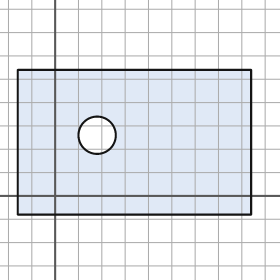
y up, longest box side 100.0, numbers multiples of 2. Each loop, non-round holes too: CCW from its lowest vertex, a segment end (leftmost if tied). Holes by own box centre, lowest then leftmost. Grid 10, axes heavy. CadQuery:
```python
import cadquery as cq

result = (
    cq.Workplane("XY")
    .moveTo(-16.0, -8.0)
    .lineTo(84.0, -8.0)
    .lineTo(84.0, 54.0)
    .lineTo(-16.0, 54.0)
    .close()
    .moveTo(18.0, 26.0)
    .circle(8.0)
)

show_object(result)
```